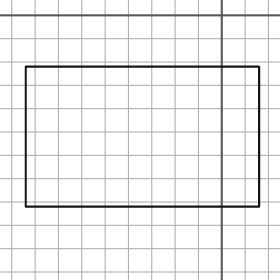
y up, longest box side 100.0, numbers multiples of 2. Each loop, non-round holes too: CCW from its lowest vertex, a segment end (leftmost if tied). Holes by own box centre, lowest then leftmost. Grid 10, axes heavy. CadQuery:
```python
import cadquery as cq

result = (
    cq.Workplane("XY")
    .moveTo(-84.0, -82.0)
    .lineTo(16.0, -82.0)
    .lineTo(16.0, -22.0)
    .lineTo(-84.0, -22.0)
    .close()
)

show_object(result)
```